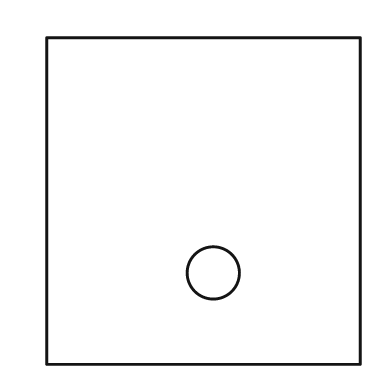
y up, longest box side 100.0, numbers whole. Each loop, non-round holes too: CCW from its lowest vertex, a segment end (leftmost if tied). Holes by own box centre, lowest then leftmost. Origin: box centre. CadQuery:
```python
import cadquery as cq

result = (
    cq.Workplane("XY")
    .moveTo(-48.0, -50.0)
    .lineTo(48.0, -50.0)
    .lineTo(48.0, 50.0)
    .lineTo(-48.0, 50.0)
    .close()
    .moveTo(3.0, -22.0)
    .circle(8.0)
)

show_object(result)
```